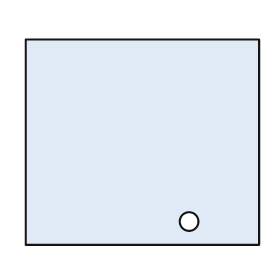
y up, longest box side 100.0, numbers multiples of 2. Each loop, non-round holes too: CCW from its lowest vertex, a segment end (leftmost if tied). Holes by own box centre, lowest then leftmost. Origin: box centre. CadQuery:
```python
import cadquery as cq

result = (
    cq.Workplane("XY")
    .moveTo(-50.0, -44.0)
    .lineTo(50.0, -44.0)
    .lineTo(50.0, 44.0)
    .lineTo(-50.0, 44.0)
    .close()
    .moveTo(20.0, -34.0)
    .circle(4.0)
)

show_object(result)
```